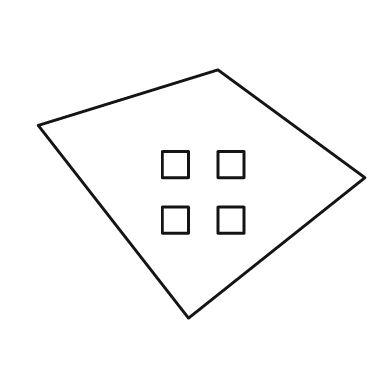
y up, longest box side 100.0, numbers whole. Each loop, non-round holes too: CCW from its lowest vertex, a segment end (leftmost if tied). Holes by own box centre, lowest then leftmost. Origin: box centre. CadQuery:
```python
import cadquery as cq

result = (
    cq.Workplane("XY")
    .moveTo(-4.0, -38.0)
    .lineTo(50.0, 5.0)
    .lineTo(5.0, 38.0)
    .lineTo(-50.0, 21.0)
    .close()
    .moveTo(-12.0, -12.0)
    .lineTo(-4.0, -12.0)
    .lineTo(-4.0, -4.0)
    .lineTo(-12.0, -4.0)
    .close()
    .moveTo(5.0, -12.0)
    .lineTo(13.0, -12.0)
    .lineTo(13.0, -4.0)
    .lineTo(5.0, -4.0)
    .close()
    .moveTo(-12.0, 5.0)
    .lineTo(-4.0, 5.0)
    .lineTo(-4.0, 13.0)
    .lineTo(-12.0, 13.0)
    .close()
    .moveTo(5.0, 5.0)
    .lineTo(13.0, 5.0)
    .lineTo(13.0, 13.0)
    .lineTo(5.0, 13.0)
    .close()
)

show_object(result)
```